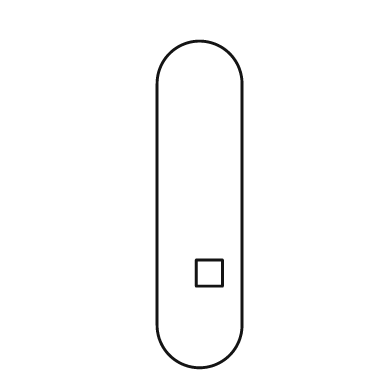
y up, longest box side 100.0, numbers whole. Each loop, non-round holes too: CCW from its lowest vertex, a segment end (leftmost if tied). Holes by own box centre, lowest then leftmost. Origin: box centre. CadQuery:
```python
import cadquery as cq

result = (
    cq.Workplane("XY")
    .moveTo(-13.0, -37.0)
    .threePointArc((0.0, -50.0), (13.0, -37.0))
    .lineTo(13.0, 37.0)
    .threePointArc((0.0, 50.0), (-13.0, 37.0))
    .close()
    .moveTo(-1.0, -25.0)
    .lineTo(7.0, -25.0)
    .lineTo(7.0, -17.0)
    .lineTo(-1.0, -17.0)
    .close()
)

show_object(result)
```